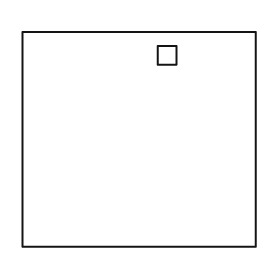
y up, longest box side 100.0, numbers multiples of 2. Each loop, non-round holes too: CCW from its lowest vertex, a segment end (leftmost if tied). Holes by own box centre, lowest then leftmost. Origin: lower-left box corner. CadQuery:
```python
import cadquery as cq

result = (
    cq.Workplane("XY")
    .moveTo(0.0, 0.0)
    .lineTo(100.0, 0.0)
    .lineTo(100.0, 92.0)
    .lineTo(0.0, 92.0)
    .close()
    .moveTo(58.0, 78.0)
    .lineTo(66.0, 78.0)
    .lineTo(66.0, 86.0)
    .lineTo(58.0, 86.0)
    .close()
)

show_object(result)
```